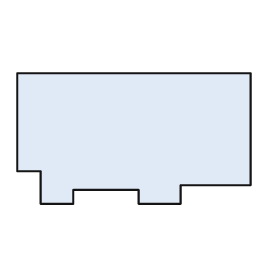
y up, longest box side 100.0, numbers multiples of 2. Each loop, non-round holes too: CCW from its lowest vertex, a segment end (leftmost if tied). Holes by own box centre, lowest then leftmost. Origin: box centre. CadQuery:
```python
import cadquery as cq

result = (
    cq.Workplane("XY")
    .moveTo(-40.0, -28.0)
    .lineTo(-26.0, -28.0)
    .lineTo(-26.0, -22.0)
    .lineTo(2.0, -22.0)
    .lineTo(2.0, -28.0)
    .lineTo(20.0, -28.0)
    .lineTo(20.0, -20.0)
    .lineTo(50.0, -20.0)
    .lineTo(50.0, 28.0)
    .lineTo(-50.0, 28.0)
    .lineTo(-50.0, -14.0)
    .lineTo(-40.0, -14.0)
    .close()
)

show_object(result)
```